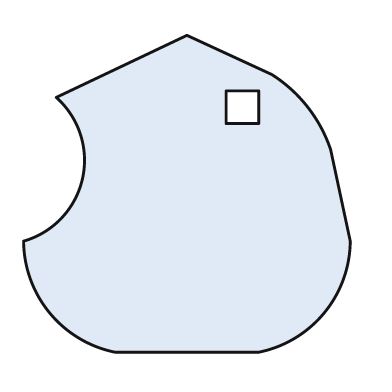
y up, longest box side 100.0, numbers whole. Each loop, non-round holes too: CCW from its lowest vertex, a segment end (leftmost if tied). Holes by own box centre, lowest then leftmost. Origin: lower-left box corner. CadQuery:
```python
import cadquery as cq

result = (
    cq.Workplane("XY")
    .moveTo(28.0, 0.0)
    .lineTo(72.0, 0.0)
    .threePointArc((92.0, 12.0), (100.0, 34.0))
    .lineTo(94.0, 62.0)
    .threePointArc((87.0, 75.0), (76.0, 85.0))
    .lineTo(50.0, 97.0)
    .lineTo(10.0, 78.0)
    .threePointArc((18.0, 53.0), (0.0, 34.0))
    .threePointArc((8.0, 12.0), (28.0, 0.0))
    .close()
    .moveTo(62.0, 70.0)
    .lineTo(72.0, 70.0)
    .lineTo(72.0, 80.0)
    .lineTo(62.0, 80.0)
    .close()
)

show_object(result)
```